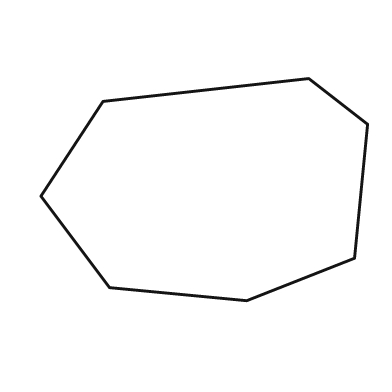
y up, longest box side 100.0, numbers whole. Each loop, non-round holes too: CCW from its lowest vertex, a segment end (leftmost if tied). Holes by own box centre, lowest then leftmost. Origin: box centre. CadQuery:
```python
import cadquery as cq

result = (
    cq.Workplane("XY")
    .moveTo(13.0, -34.0)
    .lineTo(46.0, -21.0)
    .lineTo(50.0, 20.0)
    .lineTo(32.0, 34.0)
    .lineTo(-31.0, 27.0)
    .lineTo(-50.0, -2.0)
    .lineTo(-29.0, -30.0)
    .close()
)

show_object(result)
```